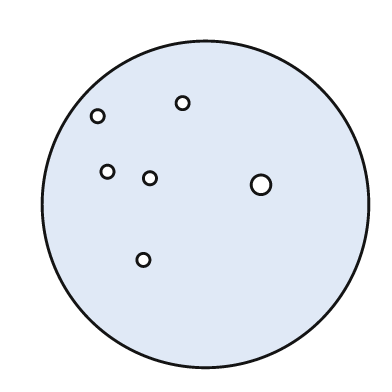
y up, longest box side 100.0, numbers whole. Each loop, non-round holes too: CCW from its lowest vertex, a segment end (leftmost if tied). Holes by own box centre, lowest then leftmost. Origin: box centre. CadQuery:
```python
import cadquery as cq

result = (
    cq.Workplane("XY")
    .moveTo(0.0, 0.0)
    .circle(50.0)
    .moveTo(-19.0, -17.0)
    .circle(2.0)
    .moveTo(17.0, 6.0)
    .circle(3.0)
    .moveTo(-17.0, 8.0)
    .circle(2.0)
    .moveTo(-30.0, 10.0)
    .circle(2.0)
    .moveTo(-33.0, 27.0)
    .circle(2.0)
    .moveTo(-7.0, 31.0)
    .circle(2.0)
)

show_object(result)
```